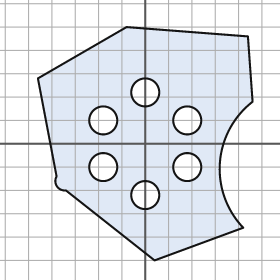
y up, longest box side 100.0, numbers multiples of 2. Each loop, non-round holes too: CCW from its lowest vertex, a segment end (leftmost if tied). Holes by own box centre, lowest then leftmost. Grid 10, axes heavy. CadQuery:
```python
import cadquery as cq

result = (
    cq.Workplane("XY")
    .moveTo(4.0, -50.0)
    .lineTo(42.0, -36.0)
    .threePointArc((32.0, -8.0), (46.0, 18.0))
    .lineTo(44.0, 46.0)
    .lineTo(-8.0, 50.0)
    .lineTo(-46.0, 28.0)
    .lineTo(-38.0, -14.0)
    .threePointArc((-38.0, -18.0), (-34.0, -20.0))
    .close()
    .moveTo(0.0, -22.0)
    .circle(6.0)
    .moveTo(-18.0, -10.0)
    .circle(6.0)
    .moveTo(18.0, -10.0)
    .circle(6.0)
    .moveTo(-18.0, 10.0)
    .circle(6.0)
    .moveTo(18.0, 10.0)
    .circle(6.0)
    .moveTo(0.0, 22.0)
    .circle(6.0)
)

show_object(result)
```